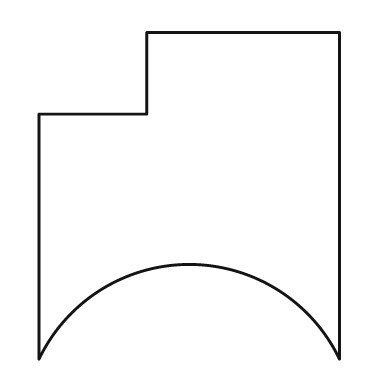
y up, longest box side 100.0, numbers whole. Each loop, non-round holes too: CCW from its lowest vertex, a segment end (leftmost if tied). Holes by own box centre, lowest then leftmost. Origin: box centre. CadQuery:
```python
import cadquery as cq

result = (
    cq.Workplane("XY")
    .moveTo(-46.0, -50.0)
    .threePointArc((0.0, -21.0), (46.0, -50.0))
    .lineTo(46.0, 50.0)
    .lineTo(-13.0, 50.0)
    .lineTo(-13.0, 25.0)
    .lineTo(-46.0, 25.0)
    .close()
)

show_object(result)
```